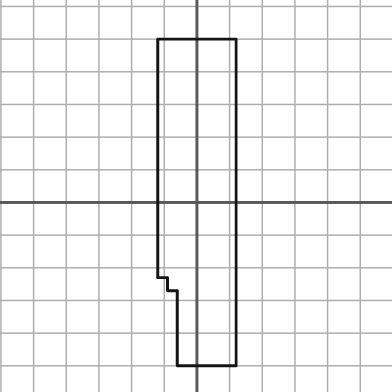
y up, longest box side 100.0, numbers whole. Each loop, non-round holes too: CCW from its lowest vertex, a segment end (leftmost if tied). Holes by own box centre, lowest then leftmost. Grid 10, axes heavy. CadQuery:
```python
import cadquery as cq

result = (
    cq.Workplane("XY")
    .moveTo(-6.0, -50.0)
    .lineTo(12.0, -50.0)
    .lineTo(12.0, 50.0)
    .lineTo(-12.0, 50.0)
    .lineTo(-12.0, -23.0)
    .lineTo(-9.0, -23.0)
    .lineTo(-9.0, -27.0)
    .lineTo(-6.0, -27.0)
    .close()
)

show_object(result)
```